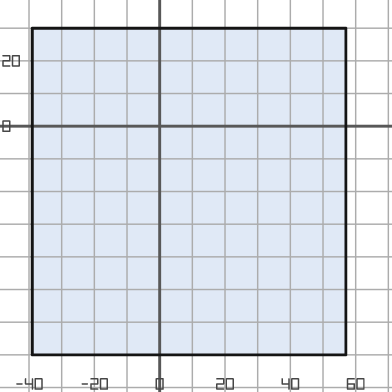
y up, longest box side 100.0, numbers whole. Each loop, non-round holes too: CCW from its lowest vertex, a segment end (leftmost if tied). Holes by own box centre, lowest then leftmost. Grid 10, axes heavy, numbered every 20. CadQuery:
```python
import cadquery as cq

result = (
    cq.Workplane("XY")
    .moveTo(-39.0, -70.0)
    .lineTo(57.0, -70.0)
    .lineTo(57.0, 30.0)
    .lineTo(-39.0, 30.0)
    .close()
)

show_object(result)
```